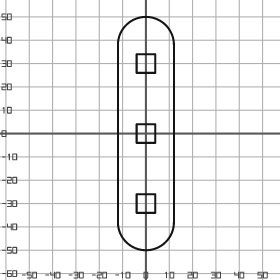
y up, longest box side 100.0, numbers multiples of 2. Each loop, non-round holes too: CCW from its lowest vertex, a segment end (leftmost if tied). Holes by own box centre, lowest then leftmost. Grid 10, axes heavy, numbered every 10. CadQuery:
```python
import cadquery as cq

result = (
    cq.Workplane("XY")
    .moveTo(-12.0, -38.0)
    .threePointArc((0.0, -50.0), (12.0, -38.0))
    .lineTo(12.0, 38.0)
    .threePointArc((0.0, 50.0), (-12.0, 38.0))
    .close()
    .moveTo(-4.0, -34.0)
    .lineTo(4.0, -34.0)
    .lineTo(4.0, -26.0)
    .lineTo(-4.0, -26.0)
    .close()
    .moveTo(-4.0, -4.0)
    .lineTo(4.0, -4.0)
    .lineTo(4.0, 4.0)
    .lineTo(-4.0, 4.0)
    .close()
    .moveTo(-4.0, 26.0)
    .lineTo(4.0, 26.0)
    .lineTo(4.0, 34.0)
    .lineTo(-4.0, 34.0)
    .close()
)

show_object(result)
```